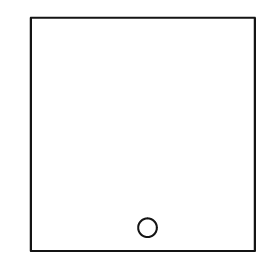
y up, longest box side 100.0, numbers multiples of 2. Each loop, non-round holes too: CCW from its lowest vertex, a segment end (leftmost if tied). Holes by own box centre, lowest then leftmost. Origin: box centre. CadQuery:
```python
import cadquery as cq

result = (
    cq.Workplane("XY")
    .moveTo(-48.0, -50.0)
    .lineTo(48.0, -50.0)
    .lineTo(48.0, 50.0)
    .lineTo(-48.0, 50.0)
    .close()
    .moveTo(2.0, -40.0)
    .circle(4.0)
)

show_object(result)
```